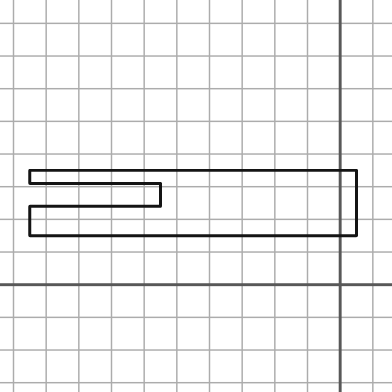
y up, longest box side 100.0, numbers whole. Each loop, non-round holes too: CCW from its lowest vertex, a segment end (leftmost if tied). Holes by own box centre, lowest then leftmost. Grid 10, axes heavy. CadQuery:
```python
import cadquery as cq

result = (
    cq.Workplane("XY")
    .moveTo(-95.0, 15.0)
    .lineTo(5.0, 15.0)
    .lineTo(5.0, 35.0)
    .lineTo(-95.0, 35.0)
    .lineTo(-95.0, 31.0)
    .lineTo(-55.0, 31.0)
    .lineTo(-55.0, 24.0)
    .lineTo(-95.0, 24.0)
    .close()
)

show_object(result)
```